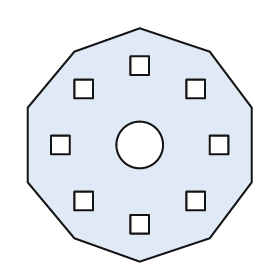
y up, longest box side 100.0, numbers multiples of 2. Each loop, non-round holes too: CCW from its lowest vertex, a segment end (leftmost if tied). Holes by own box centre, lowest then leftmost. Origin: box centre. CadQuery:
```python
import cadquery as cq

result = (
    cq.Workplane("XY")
    .moveTo(0.0, -50.0)
    .lineTo(30.0, -40.0)
    .lineTo(48.0, -16.0)
    .lineTo(48.0, 16.0)
    .lineTo(30.0, 40.0)
    .lineTo(0.0, 50.0)
    .lineTo(-28.0, 40.0)
    .lineTo(-48.0, 16.0)
    .lineTo(-48.0, -16.0)
    .lineTo(-28.0, -40.0)
    .close()
    .moveTo(-4.0, -38.0)
    .lineTo(4.0, -38.0)
    .lineTo(4.0, -30.0)
    .lineTo(-4.0, -30.0)
    .close()
    .moveTo(-28.0, -28.0)
    .lineTo(-20.0, -28.0)
    .lineTo(-20.0, -20.0)
    .lineTo(-28.0, -20.0)
    .close()
    .moveTo(20.0, -28.0)
    .lineTo(28.0, -28.0)
    .lineTo(28.0, -20.0)
    .lineTo(20.0, -20.0)
    .close()
    .moveTo(-38.0, -4.0)
    .lineTo(-30.0, -4.0)
    .lineTo(-30.0, 4.0)
    .lineTo(-38.0, 4.0)
    .close()
    .moveTo(0.0, 0.0)
    .circle(10.0)
    .moveTo(30.0, -4.0)
    .lineTo(38.0, -4.0)
    .lineTo(38.0, 4.0)
    .lineTo(30.0, 4.0)
    .close()
    .moveTo(-28.0, 20.0)
    .lineTo(-20.0, 20.0)
    .lineTo(-20.0, 28.0)
    .lineTo(-28.0, 28.0)
    .close()
    .moveTo(20.0, 20.0)
    .lineTo(28.0, 20.0)
    .lineTo(28.0, 28.0)
    .lineTo(20.0, 28.0)
    .close()
    .moveTo(-4.0, 30.0)
    .lineTo(4.0, 30.0)
    .lineTo(4.0, 38.0)
    .lineTo(-4.0, 38.0)
    .close()
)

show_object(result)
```